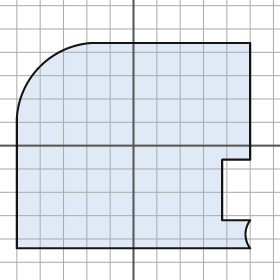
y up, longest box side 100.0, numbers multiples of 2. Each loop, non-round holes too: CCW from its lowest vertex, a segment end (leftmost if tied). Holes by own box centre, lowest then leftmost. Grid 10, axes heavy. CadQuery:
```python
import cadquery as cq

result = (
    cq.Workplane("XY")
    .moveTo(-50.0, -44.0)
    .lineTo(50.0, -44.0)
    .threePointArc((48.0, -38.0), (50.0, -32.0))
    .lineTo(38.0, -32.0)
    .lineTo(38.0, -6.0)
    .lineTo(50.0, -6.0)
    .lineTo(50.0, 44.0)
    .lineTo(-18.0, 44.0)
    .threePointArc((-40.0, 34.0), (-50.0, 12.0))
    .close()
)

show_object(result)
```